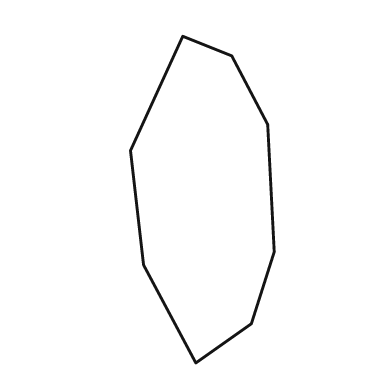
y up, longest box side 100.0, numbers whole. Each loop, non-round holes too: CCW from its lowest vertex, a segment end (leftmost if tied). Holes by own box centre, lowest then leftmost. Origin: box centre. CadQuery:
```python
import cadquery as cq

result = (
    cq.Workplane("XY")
    .moveTo(-2.0, -50.0)
    .lineTo(15.0, -38.0)
    .lineTo(22.0, -16.0)
    .lineTo(20.0, 23.0)
    .lineTo(9.0, 44.0)
    .lineTo(-6.0, 50.0)
    .lineTo(-22.0, 15.0)
    .lineTo(-18.0, -20.0)
    .close()
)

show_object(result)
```